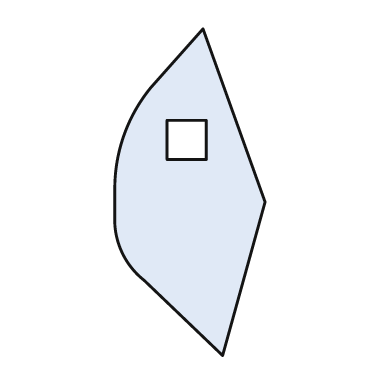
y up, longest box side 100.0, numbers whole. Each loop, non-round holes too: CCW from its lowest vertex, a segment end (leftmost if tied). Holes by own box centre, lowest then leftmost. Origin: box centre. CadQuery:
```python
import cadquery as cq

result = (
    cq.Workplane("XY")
    .moveTo(10.0, -50.0)
    .lineTo(23.0, -3.0)
    .lineTo(4.0, 50.0)
    .lineTo(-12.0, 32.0)
    .threePointArc((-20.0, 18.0), (-23.0, 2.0))
    .lineTo(-23.0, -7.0)
    .threePointArc((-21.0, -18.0), (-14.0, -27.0))
    .close()
    .moveTo(-7.0, 10.0)
    .lineTo(5.0, 10.0)
    .lineTo(5.0, 22.0)
    .lineTo(-7.0, 22.0)
    .close()
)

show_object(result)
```